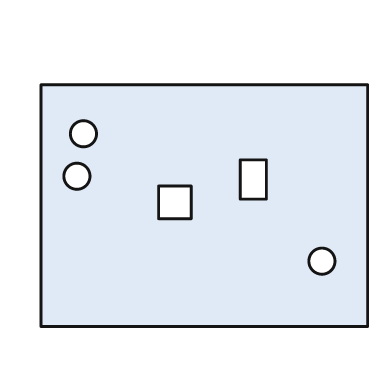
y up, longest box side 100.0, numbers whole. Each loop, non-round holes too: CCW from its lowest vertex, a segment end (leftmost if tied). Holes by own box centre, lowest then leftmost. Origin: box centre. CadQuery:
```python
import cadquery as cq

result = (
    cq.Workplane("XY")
    .moveTo(-50.0, -37.0)
    .lineTo(50.0, -37.0)
    .lineTo(50.0, 37.0)
    .lineTo(-50.0, 37.0)
    .close()
    .moveTo(36.0, -17.0)
    .circle(4.0)
    .moveTo(-14.0, -4.0)
    .lineTo(-4.0, -4.0)
    .lineTo(-4.0, 6.0)
    .lineTo(-14.0, 6.0)
    .close()
    .moveTo(11.0, 2.0)
    .lineTo(19.0, 2.0)
    .lineTo(19.0, 14.0)
    .lineTo(11.0, 14.0)
    .close()
    .moveTo(-39.0, 9.0)
    .circle(4.0)
    .moveTo(-37.0, 22.0)
    .circle(4.0)
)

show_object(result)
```